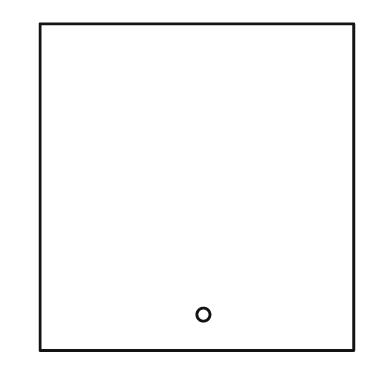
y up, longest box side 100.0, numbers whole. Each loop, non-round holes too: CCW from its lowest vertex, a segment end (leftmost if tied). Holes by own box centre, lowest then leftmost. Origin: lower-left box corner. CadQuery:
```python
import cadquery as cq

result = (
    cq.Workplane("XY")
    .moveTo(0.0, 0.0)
    .lineTo(96.0, 0.0)
    .lineTo(96.0, 100.0)
    .lineTo(0.0, 100.0)
    .close()
    .moveTo(50.0, 11.0)
    .circle(2.0)
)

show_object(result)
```